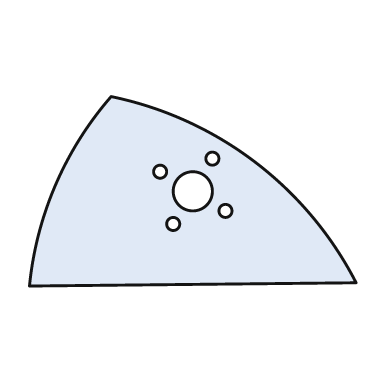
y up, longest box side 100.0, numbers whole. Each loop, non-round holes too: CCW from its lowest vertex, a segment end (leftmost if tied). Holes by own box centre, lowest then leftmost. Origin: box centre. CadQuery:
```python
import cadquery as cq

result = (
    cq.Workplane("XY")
    .moveTo(-50.0, -29.0)
    .lineTo(50.0, -28.0)
    .threePointArc((19.0, 9.0), (-25.0, 29.0))
    .threePointArc((-42.0, 2.0), (-50.0, -29.0))
    .close()
    .moveTo(-6.0, -10.0)
    .circle(2.0)
    .moveTo(10.0, -6.0)
    .circle(2.0)
    .moveTo(0.0, 0.0)
    .circle(6.0)
    .moveTo(-10.0, 6.0)
    .circle(2.0)
    .moveTo(6.0, 10.0)
    .circle(2.0)
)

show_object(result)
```